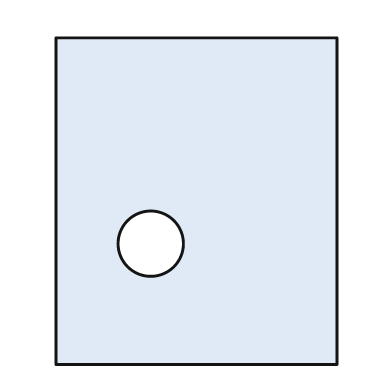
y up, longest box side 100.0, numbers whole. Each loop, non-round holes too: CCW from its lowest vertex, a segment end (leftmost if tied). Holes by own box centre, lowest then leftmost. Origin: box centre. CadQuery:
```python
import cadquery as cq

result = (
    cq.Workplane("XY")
    .moveTo(-43.0, -50.0)
    .lineTo(43.0, -50.0)
    .lineTo(43.0, 50.0)
    .lineTo(-43.0, 50.0)
    .close()
    .moveTo(-14.0, -13.0)
    .circle(10.0)
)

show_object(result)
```